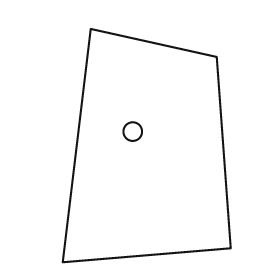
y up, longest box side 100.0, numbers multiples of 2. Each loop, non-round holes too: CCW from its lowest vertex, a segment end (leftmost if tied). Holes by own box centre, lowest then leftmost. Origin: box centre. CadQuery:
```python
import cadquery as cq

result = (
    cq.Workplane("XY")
    .moveTo(-36.0, -50.0)
    .lineTo(36.0, -44.0)
    .lineTo(30.0, 38.0)
    .lineTo(-24.0, 50.0)
    .close()
    .moveTo(-6.0, 6.0)
    .circle(4.0)
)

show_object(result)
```